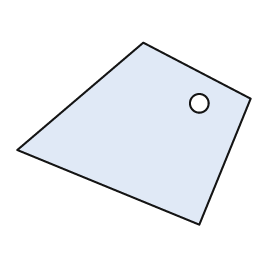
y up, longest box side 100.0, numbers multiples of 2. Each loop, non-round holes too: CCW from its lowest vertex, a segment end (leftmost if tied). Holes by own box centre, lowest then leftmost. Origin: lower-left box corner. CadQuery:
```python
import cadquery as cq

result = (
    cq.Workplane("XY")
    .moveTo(78.0, 0.0)
    .lineTo(100.0, 54.0)
    .lineTo(54.0, 78.0)
    .lineTo(0.0, 32.0)
    .close()
    .moveTo(78.0, 52.0)
    .circle(4.0)
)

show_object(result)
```